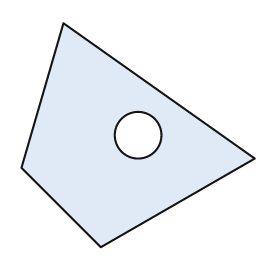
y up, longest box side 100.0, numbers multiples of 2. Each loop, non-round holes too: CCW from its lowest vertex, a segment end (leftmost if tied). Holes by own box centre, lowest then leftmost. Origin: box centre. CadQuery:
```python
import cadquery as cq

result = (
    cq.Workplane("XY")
    .moveTo(-16.0, -48.0)
    .lineTo(50.0, -10.0)
    .lineTo(-32.0, 48.0)
    .lineTo(-50.0, -14.0)
    .close()
    .moveTo(0.0, 0.0)
    .circle(10.0)
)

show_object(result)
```